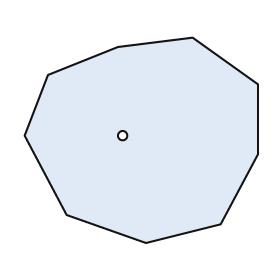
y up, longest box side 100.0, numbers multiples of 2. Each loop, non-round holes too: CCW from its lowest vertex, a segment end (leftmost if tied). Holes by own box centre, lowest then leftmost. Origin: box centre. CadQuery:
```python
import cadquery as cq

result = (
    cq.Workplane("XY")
    .moveTo(2.0, -44.0)
    .lineTo(34.0, -36.0)
    .lineTo(50.0, -6.0)
    .lineTo(50.0, 24.0)
    .lineTo(22.0, 44.0)
    .lineTo(-10.0, 40.0)
    .lineTo(-40.0, 28.0)
    .lineTo(-50.0, 2.0)
    .lineTo(-32.0, -32.0)
    .close()
    .moveTo(-8.0, 2.0)
    .circle(2.0)
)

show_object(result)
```